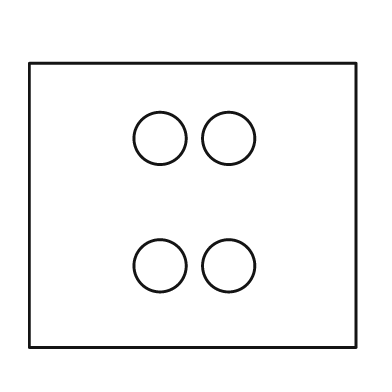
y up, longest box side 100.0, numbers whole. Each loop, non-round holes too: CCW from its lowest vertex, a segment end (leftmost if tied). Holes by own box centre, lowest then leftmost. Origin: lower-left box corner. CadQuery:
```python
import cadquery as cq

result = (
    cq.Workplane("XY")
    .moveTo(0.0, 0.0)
    .lineTo(100.0, 0.0)
    .lineTo(100.0, 87.0)
    .lineTo(0.0, 87.0)
    .close()
    .moveTo(40.0, 25.0)
    .circle(8.0)
    .moveTo(61.0, 25.0)
    .circle(8.0)
    .moveTo(40.0, 64.0)
    .circle(8.0)
    .moveTo(61.0, 64.0)
    .circle(8.0)
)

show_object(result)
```